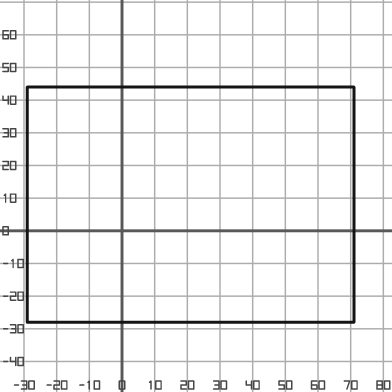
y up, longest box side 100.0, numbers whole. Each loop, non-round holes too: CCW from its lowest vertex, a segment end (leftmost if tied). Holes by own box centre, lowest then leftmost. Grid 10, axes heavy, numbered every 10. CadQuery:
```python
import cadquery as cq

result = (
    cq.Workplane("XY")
    .moveTo(-29.0, -28.0)
    .lineTo(71.0, -28.0)
    .lineTo(71.0, 44.0)
    .lineTo(-29.0, 44.0)
    .close()
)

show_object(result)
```